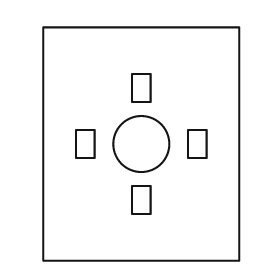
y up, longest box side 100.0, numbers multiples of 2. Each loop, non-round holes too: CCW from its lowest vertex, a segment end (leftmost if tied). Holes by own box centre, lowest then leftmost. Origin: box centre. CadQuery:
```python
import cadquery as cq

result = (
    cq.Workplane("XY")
    .moveTo(-42.0, -50.0)
    .lineTo(42.0, -50.0)
    .lineTo(42.0, 50.0)
    .lineTo(-42.0, 50.0)
    .close()
    .moveTo(-4.0, -30.0)
    .lineTo(4.0, -30.0)
    .lineTo(4.0, -18.0)
    .lineTo(-4.0, -18.0)
    .close()
    .moveTo(-28.0, -6.0)
    .lineTo(-20.0, -6.0)
    .lineTo(-20.0, 6.0)
    .lineTo(-28.0, 6.0)
    .close()
    .moveTo(0.0, 0.0)
    .circle(12.0)
    .moveTo(20.0, -6.0)
    .lineTo(28.0, -6.0)
    .lineTo(28.0, 6.0)
    .lineTo(20.0, 6.0)
    .close()
    .moveTo(-4.0, 18.0)
    .lineTo(4.0, 18.0)
    .lineTo(4.0, 30.0)
    .lineTo(-4.0, 30.0)
    .close()
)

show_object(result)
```